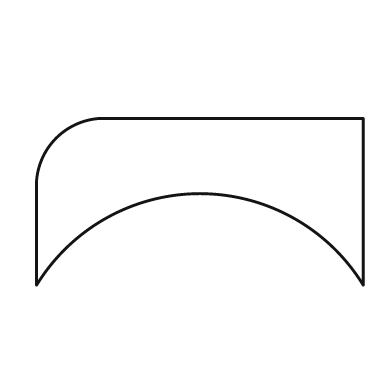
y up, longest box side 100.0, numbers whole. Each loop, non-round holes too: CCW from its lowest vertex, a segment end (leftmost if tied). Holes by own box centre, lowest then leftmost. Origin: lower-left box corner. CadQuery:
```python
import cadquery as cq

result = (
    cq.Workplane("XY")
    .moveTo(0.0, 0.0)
    .threePointArc((50.0, 28.0), (100.0, 0.0))
    .lineTo(100.0, 51.0)
    .lineTo(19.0, 51.0)
    .threePointArc((6.0, 45.0), (0.0, 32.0))
    .close()
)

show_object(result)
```